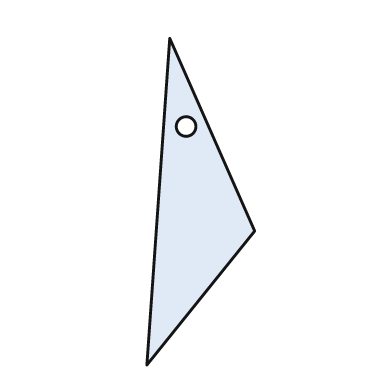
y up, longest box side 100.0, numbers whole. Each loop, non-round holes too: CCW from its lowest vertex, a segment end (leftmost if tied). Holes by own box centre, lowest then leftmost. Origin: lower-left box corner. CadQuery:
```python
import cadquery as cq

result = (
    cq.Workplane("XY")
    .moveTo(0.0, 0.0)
    .lineTo(33.0, 41.0)
    .lineTo(7.0, 100.0)
    .close()
    .moveTo(12.0, 73.0)
    .circle(3.0)
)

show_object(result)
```